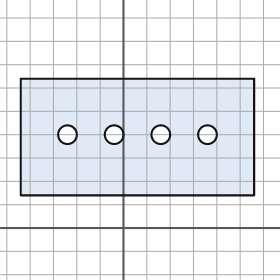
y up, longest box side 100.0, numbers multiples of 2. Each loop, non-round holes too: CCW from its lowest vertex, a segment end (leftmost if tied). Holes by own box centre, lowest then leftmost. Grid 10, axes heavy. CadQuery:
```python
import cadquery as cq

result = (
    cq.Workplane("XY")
    .moveTo(-44.0, 14.0)
    .lineTo(56.0, 14.0)
    .lineTo(56.0, 64.0)
    .lineTo(-44.0, 64.0)
    .close()
    .moveTo(-24.0, 40.0)
    .circle(4.0)
    .moveTo(-4.0, 40.0)
    .circle(4.0)
    .moveTo(16.0, 40.0)
    .circle(4.0)
    .moveTo(36.0, 40.0)
    .circle(4.0)
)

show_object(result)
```